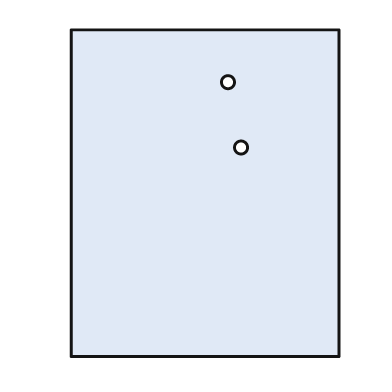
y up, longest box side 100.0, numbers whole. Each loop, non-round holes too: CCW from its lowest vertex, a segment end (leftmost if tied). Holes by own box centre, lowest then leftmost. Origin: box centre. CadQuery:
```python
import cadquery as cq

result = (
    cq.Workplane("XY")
    .moveTo(-41.0, -50.0)
    .lineTo(41.0, -50.0)
    .lineTo(41.0, 50.0)
    .lineTo(-41.0, 50.0)
    .close()
    .moveTo(11.0, 14.0)
    .circle(2.0)
    .moveTo(7.0, 34.0)
    .circle(2.0)
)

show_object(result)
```